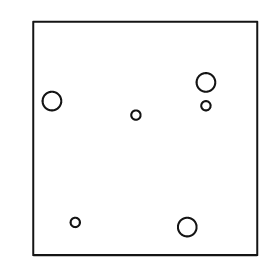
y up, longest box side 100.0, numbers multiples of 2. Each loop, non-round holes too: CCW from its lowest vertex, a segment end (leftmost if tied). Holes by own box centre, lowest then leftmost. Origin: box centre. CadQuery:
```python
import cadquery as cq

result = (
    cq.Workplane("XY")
    .moveTo(-48.0, -50.0)
    .lineTo(48.0, -50.0)
    .lineTo(48.0, 50.0)
    .lineTo(-48.0, 50.0)
    .close()
    .moveTo(18.0, -38.0)
    .circle(4.0)
    .moveTo(-30.0, -36.0)
    .circle(2.0)
    .moveTo(-4.0, 10.0)
    .circle(2.0)
    .moveTo(26.0, 14.0)
    .circle(2.0)
    .moveTo(-40.0, 16.0)
    .circle(4.0)
    .moveTo(26.0, 24.0)
    .circle(4.0)
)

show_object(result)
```